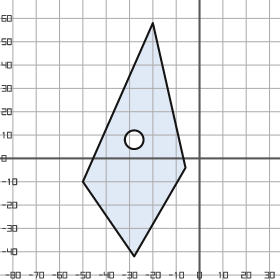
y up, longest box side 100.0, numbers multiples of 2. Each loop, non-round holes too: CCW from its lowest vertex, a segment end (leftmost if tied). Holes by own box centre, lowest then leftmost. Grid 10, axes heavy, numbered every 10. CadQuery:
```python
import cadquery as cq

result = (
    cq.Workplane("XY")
    .moveTo(-28.0, -42.0)
    .lineTo(-6.0, -4.0)
    .lineTo(-20.0, 58.0)
    .lineTo(-50.0, -10.0)
    .close()
    .moveTo(-28.0, 8.0)
    .circle(4.0)
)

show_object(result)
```